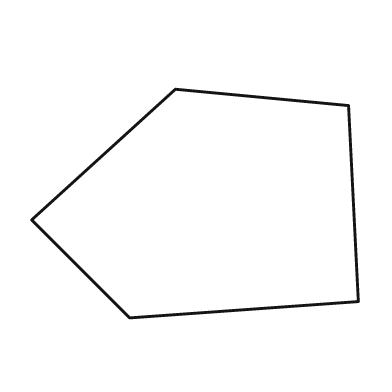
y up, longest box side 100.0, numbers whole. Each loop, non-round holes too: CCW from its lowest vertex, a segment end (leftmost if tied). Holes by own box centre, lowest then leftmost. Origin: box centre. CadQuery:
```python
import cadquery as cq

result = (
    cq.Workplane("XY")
    .moveTo(-20.0, -35.0)
    .lineTo(50.0, -30.0)
    .lineTo(47.0, 30.0)
    .lineTo(-6.0, 35.0)
    .lineTo(-50.0, -5.0)
    .close()
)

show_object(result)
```